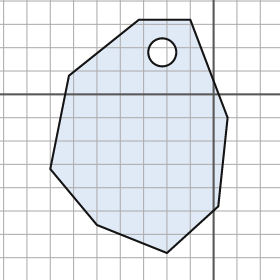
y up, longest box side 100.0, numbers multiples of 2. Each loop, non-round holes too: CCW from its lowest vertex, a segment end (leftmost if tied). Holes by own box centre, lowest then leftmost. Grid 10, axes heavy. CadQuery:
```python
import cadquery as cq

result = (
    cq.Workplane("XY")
    .moveTo(-20.0, -68.0)
    .lineTo(2.0, -48.0)
    .lineTo(6.0, -10.0)
    .lineTo(-10.0, 32.0)
    .lineTo(-32.0, 32.0)
    .lineTo(-62.0, 8.0)
    .lineTo(-70.0, -32.0)
    .lineTo(-50.0, -56.0)
    .close()
    .moveTo(-22.0, 18.0)
    .circle(6.0)
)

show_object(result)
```